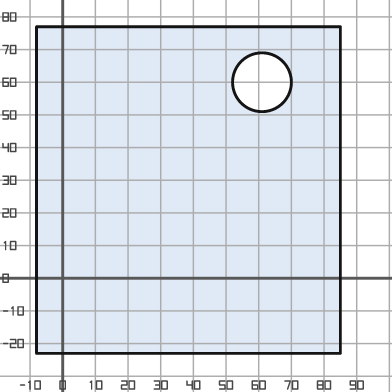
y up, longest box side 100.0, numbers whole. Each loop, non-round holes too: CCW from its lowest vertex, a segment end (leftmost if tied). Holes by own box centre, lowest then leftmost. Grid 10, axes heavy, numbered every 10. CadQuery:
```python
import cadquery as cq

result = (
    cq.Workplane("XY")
    .moveTo(-8.0, -23.0)
    .lineTo(85.0, -23.0)
    .lineTo(85.0, 77.0)
    .lineTo(-8.0, 77.0)
    .close()
    .moveTo(61.0, 60.0)
    .circle(9.0)
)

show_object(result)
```